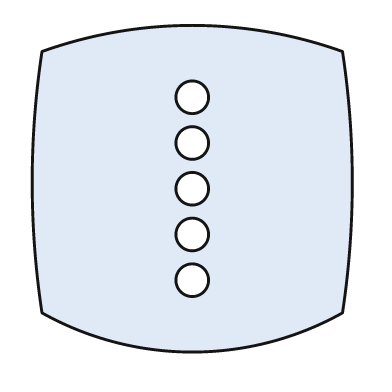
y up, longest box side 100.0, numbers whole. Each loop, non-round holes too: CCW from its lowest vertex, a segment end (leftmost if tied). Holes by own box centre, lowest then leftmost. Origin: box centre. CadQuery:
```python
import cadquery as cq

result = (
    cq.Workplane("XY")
    .moveTo(-46.0, -38.0)
    .threePointArc((0.0, -50.0), (46.0, -38.0))
    .threePointArc((49.0, 2.0), (46.0, 42.0))
    .threePointArc((0.0, 50.0), (-46.0, 42.0))
    .threePointArc((-49.0, 2.0), (-46.0, -38.0))
    .close()
    .moveTo(0.0, -28.0)
    .circle(5.0)
    .moveTo(0.0, -14.0)
    .circle(5.0)
    .moveTo(0.0, 0.0)
    .circle(5.0)
    .moveTo(0.0, 14.0)
    .circle(5.0)
    .moveTo(0.0, 28.0)
    .circle(5.0)
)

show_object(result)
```